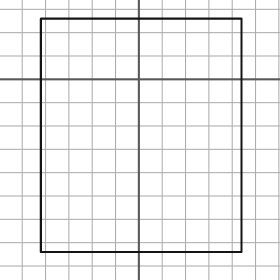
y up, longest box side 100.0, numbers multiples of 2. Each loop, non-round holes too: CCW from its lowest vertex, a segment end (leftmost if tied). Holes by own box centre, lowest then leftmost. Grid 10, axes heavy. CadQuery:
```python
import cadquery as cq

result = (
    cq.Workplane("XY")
    .moveTo(-42.0, -74.0)
    .lineTo(44.0, -74.0)
    .lineTo(44.0, 26.0)
    .lineTo(-42.0, 26.0)
    .close()
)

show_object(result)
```